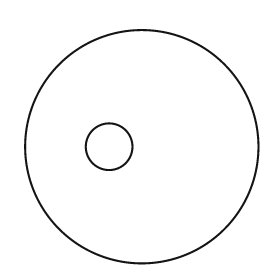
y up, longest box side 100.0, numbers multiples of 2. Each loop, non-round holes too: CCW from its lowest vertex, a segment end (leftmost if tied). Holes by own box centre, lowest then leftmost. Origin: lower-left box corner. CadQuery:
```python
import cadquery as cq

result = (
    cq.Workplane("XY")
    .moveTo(50.0, 50.0)
    .circle(50.0)
    .moveTo(36.0, 50.0)
    .circle(10.0)
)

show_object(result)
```